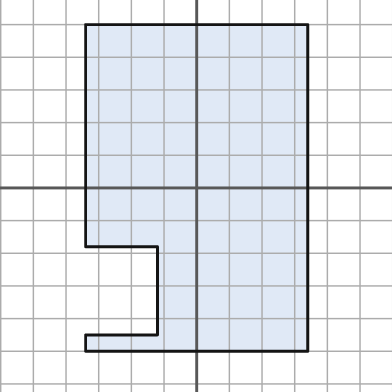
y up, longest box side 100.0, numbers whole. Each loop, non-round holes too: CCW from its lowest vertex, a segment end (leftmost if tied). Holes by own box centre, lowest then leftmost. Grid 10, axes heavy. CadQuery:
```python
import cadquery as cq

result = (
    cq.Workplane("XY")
    .moveTo(-34.0, -50.0)
    .lineTo(34.0, -50.0)
    .lineTo(34.0, 50.0)
    .lineTo(-34.0, 50.0)
    .lineTo(-34.0, -18.0)
    .lineTo(-12.0, -18.0)
    .lineTo(-12.0, -45.0)
    .lineTo(-34.0, -45.0)
    .close()
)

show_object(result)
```